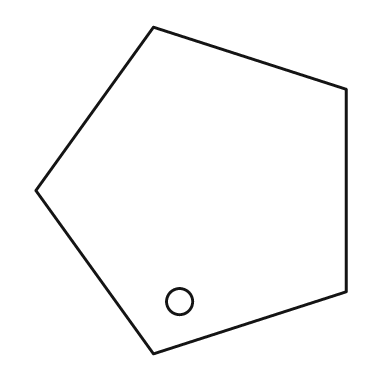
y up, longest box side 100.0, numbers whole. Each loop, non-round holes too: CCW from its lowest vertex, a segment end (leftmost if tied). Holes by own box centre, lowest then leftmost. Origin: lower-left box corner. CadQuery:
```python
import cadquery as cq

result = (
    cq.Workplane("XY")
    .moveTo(36.0, 0.0)
    .lineTo(95.0, 19.0)
    .lineTo(95.0, 81.0)
    .lineTo(36.0, 100.0)
    .lineTo(0.0, 50.0)
    .close()
    .moveTo(44.0, 16.0)
    .circle(4.0)
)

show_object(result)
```